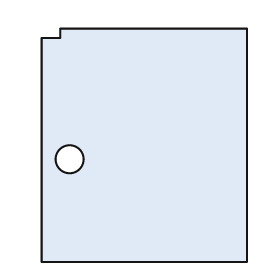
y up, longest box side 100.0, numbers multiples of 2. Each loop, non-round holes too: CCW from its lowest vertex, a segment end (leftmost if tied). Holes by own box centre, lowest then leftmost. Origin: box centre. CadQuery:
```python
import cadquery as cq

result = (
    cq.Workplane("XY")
    .moveTo(-44.0, -50.0)
    .lineTo(44.0, -50.0)
    .lineTo(44.0, 50.0)
    .lineTo(-36.0, 50.0)
    .lineTo(-36.0, 46.0)
    .lineTo(-44.0, 46.0)
    .close()
    .moveTo(-32.0, -6.0)
    .circle(6.0)
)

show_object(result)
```